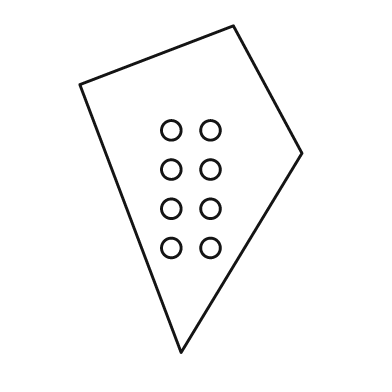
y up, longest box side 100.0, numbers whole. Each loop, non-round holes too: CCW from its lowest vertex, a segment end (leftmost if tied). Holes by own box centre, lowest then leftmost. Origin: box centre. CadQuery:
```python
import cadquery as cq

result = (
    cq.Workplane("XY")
    .moveTo(-3.0, -50.0)
    .lineTo(34.0, 11.0)
    .lineTo(13.0, 50.0)
    .lineTo(-34.0, 32.0)
    .close()
    .moveTo(-6.0, -18.0)
    .circle(3.0)
    .moveTo(6.0, -18.0)
    .circle(3.0)
    .moveTo(-6.0, -6.0)
    .circle(3.0)
    .moveTo(6.0, -6.0)
    .circle(3.0)
    .moveTo(-6.0, 6.0)
    .circle(3.0)
    .moveTo(6.0, 6.0)
    .circle(3.0)
    .moveTo(-6.0, 18.0)
    .circle(3.0)
    .moveTo(6.0, 18.0)
    .circle(3.0)
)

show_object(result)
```